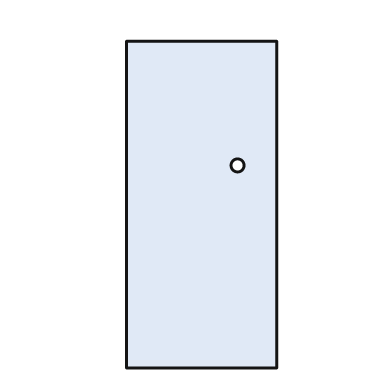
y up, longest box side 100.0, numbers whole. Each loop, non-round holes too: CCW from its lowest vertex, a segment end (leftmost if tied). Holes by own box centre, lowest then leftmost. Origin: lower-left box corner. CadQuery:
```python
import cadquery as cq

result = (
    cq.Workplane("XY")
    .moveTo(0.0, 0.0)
    .lineTo(46.0, 0.0)
    .lineTo(46.0, 100.0)
    .lineTo(0.0, 100.0)
    .close()
    .moveTo(34.0, 62.0)
    .circle(2.0)
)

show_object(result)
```